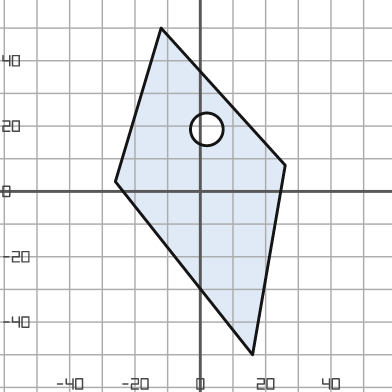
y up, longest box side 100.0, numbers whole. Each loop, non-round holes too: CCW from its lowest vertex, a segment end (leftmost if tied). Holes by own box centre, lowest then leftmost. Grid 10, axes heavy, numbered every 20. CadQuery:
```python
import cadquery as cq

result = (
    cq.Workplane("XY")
    .moveTo(16.0, -50.0)
    .lineTo(26.0, 8.0)
    .lineTo(-12.0, 50.0)
    .lineTo(-26.0, 3.0)
    .close()
    .moveTo(2.0, 19.0)
    .circle(5.0)
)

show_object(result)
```